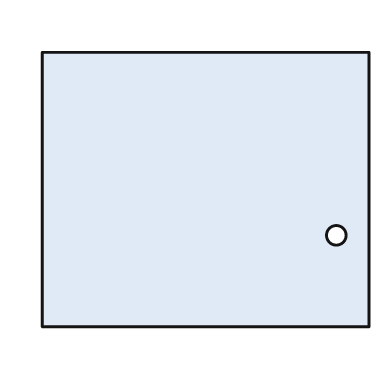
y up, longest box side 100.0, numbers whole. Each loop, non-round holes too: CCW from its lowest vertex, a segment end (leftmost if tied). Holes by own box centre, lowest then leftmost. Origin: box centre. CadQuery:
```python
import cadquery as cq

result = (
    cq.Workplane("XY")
    .moveTo(-50.0, -42.0)
    .lineTo(50.0, -42.0)
    .lineTo(50.0, 42.0)
    .lineTo(-50.0, 42.0)
    .close()
    .moveTo(40.0, -14.0)
    .circle(3.0)
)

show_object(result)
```